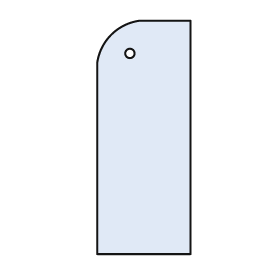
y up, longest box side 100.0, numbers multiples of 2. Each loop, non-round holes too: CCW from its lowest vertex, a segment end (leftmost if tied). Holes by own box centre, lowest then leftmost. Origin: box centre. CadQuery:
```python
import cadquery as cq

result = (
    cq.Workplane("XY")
    .moveTo(-20.0, -50.0)
    .lineTo(20.0, -50.0)
    .lineTo(20.0, 50.0)
    .lineTo(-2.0, 50.0)
    .threePointArc((-14.0, 44.0), (-20.0, 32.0))
    .close()
    .moveTo(-6.0, 36.0)
    .circle(2.0)
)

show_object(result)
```